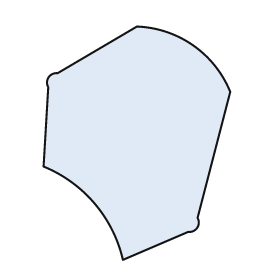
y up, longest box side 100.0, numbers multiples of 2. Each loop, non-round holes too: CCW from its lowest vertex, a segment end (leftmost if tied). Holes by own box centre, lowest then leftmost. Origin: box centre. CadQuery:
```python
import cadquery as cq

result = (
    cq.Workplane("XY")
    .moveTo(-6.0, -50.0)
    .lineTo(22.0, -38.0)
    .threePointArc((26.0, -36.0), (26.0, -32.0))
    .lineTo(40.0, 22.0)
    .threePointArc((24.0, 42.0), (0.0, 50.0))
    .lineTo(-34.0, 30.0)
    .threePointArc((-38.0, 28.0), (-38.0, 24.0))
    .lineTo(-40.0, -10.0)
    .threePointArc((-18.0, -26.0), (-6.0, -50.0))
    .close()
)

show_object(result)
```